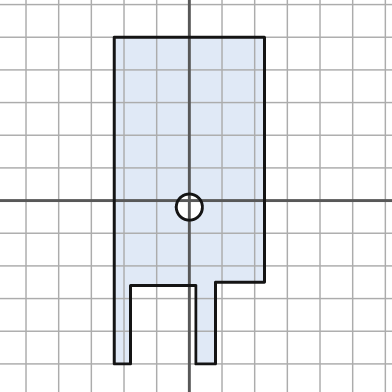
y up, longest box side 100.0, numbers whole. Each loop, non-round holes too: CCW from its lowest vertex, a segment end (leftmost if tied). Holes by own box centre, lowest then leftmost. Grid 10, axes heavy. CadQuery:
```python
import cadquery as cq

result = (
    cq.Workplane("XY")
    .moveTo(-23.0, -50.0)
    .lineTo(-18.0, -50.0)
    .lineTo(-18.0, -26.0)
    .lineTo(2.0, -26.0)
    .lineTo(2.0, -50.0)
    .lineTo(8.0, -50.0)
    .lineTo(8.0, -25.0)
    .lineTo(23.0, -25.0)
    .lineTo(23.0, 50.0)
    .lineTo(-23.0, 50.0)
    .close()
    .moveTo(0.0, -2.0)
    .circle(4.0)
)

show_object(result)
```